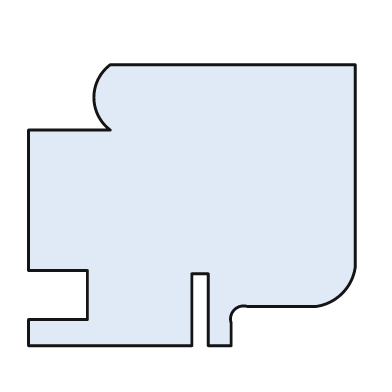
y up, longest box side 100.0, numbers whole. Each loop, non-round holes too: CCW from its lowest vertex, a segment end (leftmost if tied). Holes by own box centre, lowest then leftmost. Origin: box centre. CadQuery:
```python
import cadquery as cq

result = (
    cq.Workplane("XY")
    .moveTo(-50.0, -43.0)
    .lineTo(0.0, -43.0)
    .lineTo(0.0, -21.0)
    .lineTo(5.0, -21.0)
    .lineTo(5.0, -43.0)
    .lineTo(12.0, -43.0)
    .lineTo(12.0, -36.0)
    .threePointArc((13.0, -32.0), (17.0, -31.0))
    .lineTo(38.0, -31.0)
    .threePointArc((46.0, -27.0), (50.0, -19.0))
    .lineTo(50.0, 43.0)
    .lineTo(-25.0, 43.0)
    .threePointArc((-30.0, 33.0), (-25.0, 23.0))
    .lineTo(-50.0, 23.0)
    .lineTo(-50.0, -20.0)
    .lineTo(-32.0, -20.0)
    .lineTo(-32.0, -35.0)
    .lineTo(-50.0, -35.0)
    .close()
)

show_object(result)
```